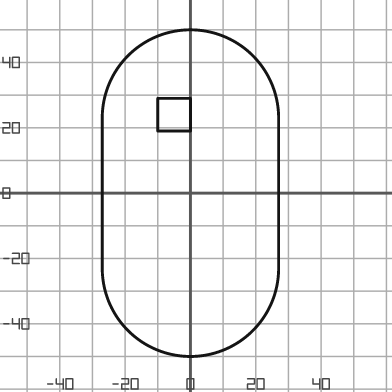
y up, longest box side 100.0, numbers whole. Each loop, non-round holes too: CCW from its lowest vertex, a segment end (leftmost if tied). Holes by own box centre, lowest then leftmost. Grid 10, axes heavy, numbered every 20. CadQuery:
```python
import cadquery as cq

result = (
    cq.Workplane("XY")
    .moveTo(-27.0, -23.0)
    .threePointArc((0.0, -50.0), (27.0, -23.0))
    .lineTo(27.0, 23.0)
    .threePointArc((0.0, 50.0), (-27.0, 23.0))
    .close()
    .moveTo(-10.0, 19.0)
    .lineTo(0.0, 19.0)
    .lineTo(0.0, 29.0)
    .lineTo(-10.0, 29.0)
    .close()
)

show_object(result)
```